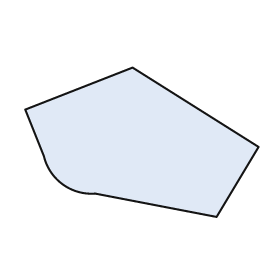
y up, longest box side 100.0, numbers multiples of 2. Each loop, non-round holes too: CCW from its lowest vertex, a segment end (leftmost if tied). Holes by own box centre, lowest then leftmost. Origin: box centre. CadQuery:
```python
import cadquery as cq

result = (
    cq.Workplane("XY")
    .moveTo(32.0, -32.0)
    .lineTo(50.0, -2.0)
    .lineTo(-4.0, 32.0)
    .lineTo(-50.0, 14.0)
    .lineTo(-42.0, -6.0)
    .threePointArc((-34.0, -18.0), (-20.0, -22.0))
    .close()
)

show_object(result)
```